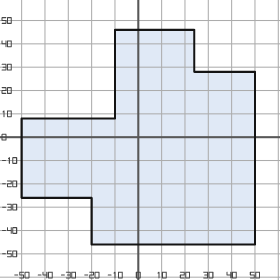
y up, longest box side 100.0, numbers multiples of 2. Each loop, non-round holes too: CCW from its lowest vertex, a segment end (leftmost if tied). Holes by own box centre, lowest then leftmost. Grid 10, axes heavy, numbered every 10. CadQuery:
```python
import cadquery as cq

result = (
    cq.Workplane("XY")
    .moveTo(-20.0, -46.0)
    .lineTo(50.0, -46.0)
    .lineTo(50.0, 28.0)
    .lineTo(24.0, 28.0)
    .lineTo(24.0, 46.0)
    .lineTo(-10.0, 46.0)
    .lineTo(-10.0, 8.0)
    .lineTo(-50.0, 8.0)
    .lineTo(-50.0, -26.0)
    .lineTo(-20.0, -26.0)
    .close()
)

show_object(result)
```